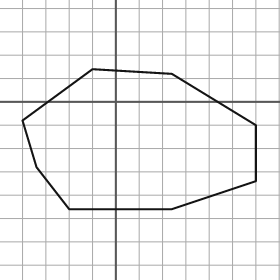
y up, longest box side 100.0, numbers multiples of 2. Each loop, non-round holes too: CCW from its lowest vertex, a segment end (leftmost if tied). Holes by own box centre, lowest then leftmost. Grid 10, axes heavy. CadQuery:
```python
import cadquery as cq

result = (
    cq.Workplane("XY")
    .moveTo(-20.0, -46.0)
    .lineTo(24.0, -46.0)
    .lineTo(60.0, -34.0)
    .lineTo(60.0, -10.0)
    .lineTo(24.0, 12.0)
    .lineTo(-10.0, 14.0)
    .lineTo(-40.0, -8.0)
    .lineTo(-34.0, -28.0)
    .close()
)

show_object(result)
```